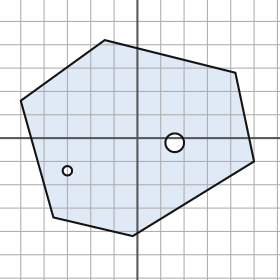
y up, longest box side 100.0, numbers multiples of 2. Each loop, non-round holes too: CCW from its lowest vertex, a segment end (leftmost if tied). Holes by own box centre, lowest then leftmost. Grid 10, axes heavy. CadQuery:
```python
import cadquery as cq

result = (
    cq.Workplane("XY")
    .moveTo(-2.0, -42.0)
    .lineTo(50.0, -10.0)
    .lineTo(42.0, 28.0)
    .lineTo(-14.0, 42.0)
    .lineTo(-50.0, 16.0)
    .lineTo(-36.0, -34.0)
    .close()
    .moveTo(-30.0, -14.0)
    .circle(2.0)
    .moveTo(16.0, -2.0)
    .circle(4.0)
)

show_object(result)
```